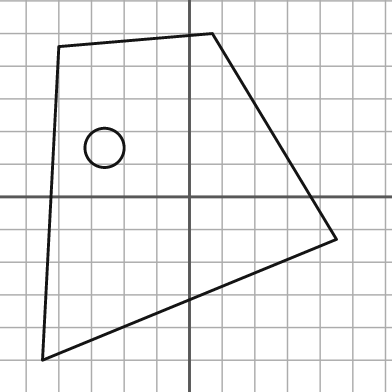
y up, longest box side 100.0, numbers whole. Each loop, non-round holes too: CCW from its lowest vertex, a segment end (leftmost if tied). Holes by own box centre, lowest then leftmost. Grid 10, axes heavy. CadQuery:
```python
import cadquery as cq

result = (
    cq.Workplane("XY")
    .moveTo(-45.0, -50.0)
    .lineTo(45.0, -13.0)
    .lineTo(7.0, 50.0)
    .lineTo(-40.0, 46.0)
    .close()
    .moveTo(-26.0, 15.0)
    .circle(6.0)
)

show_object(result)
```